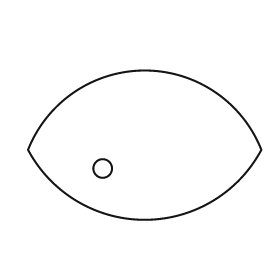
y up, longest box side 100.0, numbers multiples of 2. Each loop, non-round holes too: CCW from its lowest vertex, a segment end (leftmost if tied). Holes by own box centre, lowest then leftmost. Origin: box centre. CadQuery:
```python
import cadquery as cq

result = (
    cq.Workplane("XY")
    .moveTo(-50.0, -2.0)
    .threePointArc((0.0, -32.0), (50.0, -2.0))
    .threePointArc((0.0, 32.0), (-50.0, -2.0))
    .close()
    .moveTo(-18.0, -10.0)
    .circle(4.0)
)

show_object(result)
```